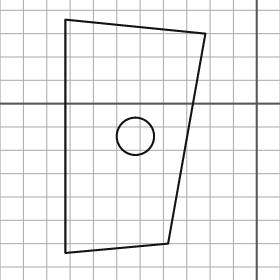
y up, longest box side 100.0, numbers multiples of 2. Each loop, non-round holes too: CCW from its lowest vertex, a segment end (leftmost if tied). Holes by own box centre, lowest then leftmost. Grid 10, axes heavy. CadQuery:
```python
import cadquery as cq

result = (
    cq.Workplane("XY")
    .moveTo(-82.0, -64.0)
    .lineTo(-38.0, -60.0)
    .lineTo(-22.0, 30.0)
    .lineTo(-82.0, 36.0)
    .close()
    .moveTo(-52.0, -14.0)
    .circle(8.0)
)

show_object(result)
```